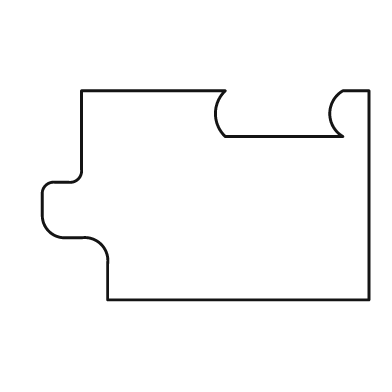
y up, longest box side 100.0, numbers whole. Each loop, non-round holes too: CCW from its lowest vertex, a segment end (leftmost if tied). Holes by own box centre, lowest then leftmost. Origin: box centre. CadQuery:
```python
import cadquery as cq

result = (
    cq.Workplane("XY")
    .moveTo(-30.0, -32.0)
    .lineTo(50.0, -32.0)
    .lineTo(50.0, 32.0)
    .lineTo(42.0, 32.0)
    .threePointArc((38.0, 25.0), (42.0, 18.0))
    .lineTo(6.0, 18.0)
    .threePointArc((3.0, 25.0), (6.0, 32.0))
    .lineTo(-38.0, 32.0)
    .lineTo(-38.0, 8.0)
    .threePointArc((-39.0, 5.0), (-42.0, 4.0))
    .lineTo(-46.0, 4.0)
    .threePointArc((-49.0, 3.0), (-50.0, 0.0))
    .lineTo(-50.0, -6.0)
    .threePointArc((-48.0, -11.0), (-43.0, -13.0))
    .lineTo(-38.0, -13.0)
    .threePointArc((-32.0, -15.0), (-30.0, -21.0))
    .close()
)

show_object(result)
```